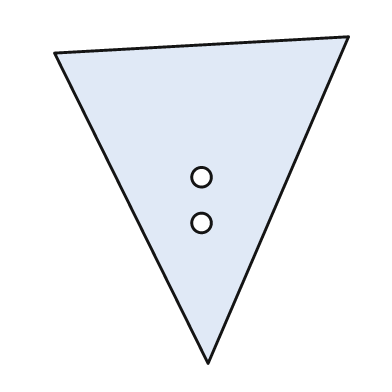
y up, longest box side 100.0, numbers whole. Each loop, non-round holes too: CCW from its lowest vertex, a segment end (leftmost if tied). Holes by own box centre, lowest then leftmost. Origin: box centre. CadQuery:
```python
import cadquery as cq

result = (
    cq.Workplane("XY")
    .moveTo(2.0, -50.0)
    .lineTo(45.0, 50.0)
    .lineTo(-45.0, 45.0)
    .close()
    .moveTo(0.0, -7.0)
    .circle(3.0)
    .moveTo(0.0, 7.0)
    .circle(3.0)
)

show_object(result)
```